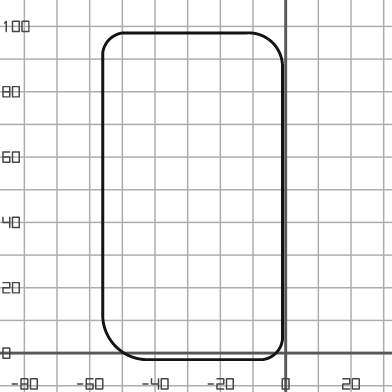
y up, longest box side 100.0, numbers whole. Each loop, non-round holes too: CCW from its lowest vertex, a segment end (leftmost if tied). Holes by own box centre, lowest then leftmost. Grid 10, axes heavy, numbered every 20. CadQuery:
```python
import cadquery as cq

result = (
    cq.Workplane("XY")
    .moveTo(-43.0, -2.0)
    .lineTo(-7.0, -2.0)
    .threePointArc((-3.0, 0.0), (-1.0, 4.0))
    .lineTo(-1.0, 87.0)
    .threePointArc((-4.0, 95.0), (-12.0, 98.0))
    .lineTo(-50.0, 98.0)
    .threePointArc((-54.0, 96.0), (-56.0, 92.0))
    .lineTo(-56.0, 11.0)
    .threePointArc((-52.0, 2.0), (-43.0, -2.0))
    .close()
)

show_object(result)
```